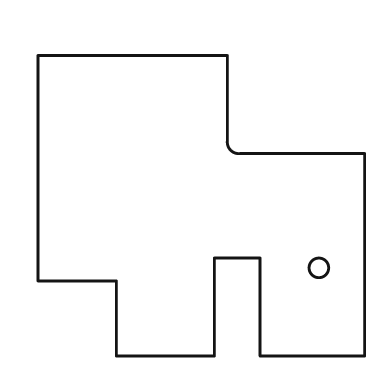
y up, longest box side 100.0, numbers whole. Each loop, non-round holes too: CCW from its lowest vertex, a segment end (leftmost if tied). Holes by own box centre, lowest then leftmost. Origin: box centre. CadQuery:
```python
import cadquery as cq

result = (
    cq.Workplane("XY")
    .moveTo(-26.0, -46.0)
    .lineTo(4.0, -46.0)
    .lineTo(4.0, -16.0)
    .lineTo(18.0, -16.0)
    .lineTo(18.0, -46.0)
    .lineTo(50.0, -46.0)
    .lineTo(50.0, 16.0)
    .lineTo(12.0, 16.0)
    .threePointArc((9.0, 17.0), (8.0, 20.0))
    .lineTo(8.0, 46.0)
    .lineTo(-50.0, 46.0)
    .lineTo(-50.0, -23.0)
    .lineTo(-26.0, -23.0)
    .close()
    .moveTo(36.0, -19.0)
    .circle(3.0)
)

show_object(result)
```